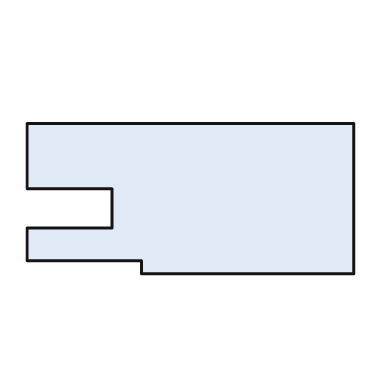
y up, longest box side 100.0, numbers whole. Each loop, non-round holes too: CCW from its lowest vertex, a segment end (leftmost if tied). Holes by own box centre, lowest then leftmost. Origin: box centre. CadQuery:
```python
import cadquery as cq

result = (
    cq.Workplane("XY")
    .moveTo(-15.0, -23.0)
    .lineTo(50.0, -23.0)
    .lineTo(50.0, 23.0)
    .lineTo(-50.0, 23.0)
    .lineTo(-50.0, 3.0)
    .lineTo(-24.0, 3.0)
    .lineTo(-24.0, -9.0)
    .lineTo(-50.0, -9.0)
    .lineTo(-50.0, -19.0)
    .lineTo(-15.0, -19.0)
    .close()
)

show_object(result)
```